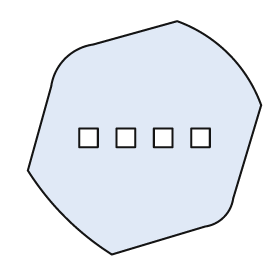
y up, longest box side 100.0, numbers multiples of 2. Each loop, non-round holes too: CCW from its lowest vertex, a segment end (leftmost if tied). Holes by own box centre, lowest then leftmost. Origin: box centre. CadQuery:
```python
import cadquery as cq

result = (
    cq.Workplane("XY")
    .moveTo(-14.0, -50.0)
    .lineTo(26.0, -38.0)
    .threePointArc((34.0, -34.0), (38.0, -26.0))
    .lineTo(50.0, 14.0)
    .threePointArc((36.0, 36.0), (14.0, 50.0))
    .lineTo(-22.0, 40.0)
    .threePointArc((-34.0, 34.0), (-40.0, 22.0))
    .lineTo(-50.0, -14.0)
    .threePointArc((-34.0, -34.0), (-14.0, -50.0))
    .close()
    .moveTo(-28.0, -4.0)
    .lineTo(-20.0, -4.0)
    .lineTo(-20.0, 4.0)
    .lineTo(-28.0, 4.0)
    .close()
    .moveTo(-12.0, -4.0)
    .lineTo(-4.0, -4.0)
    .lineTo(-4.0, 4.0)
    .lineTo(-12.0, 4.0)
    .close()
    .moveTo(4.0, -4.0)
    .lineTo(12.0, -4.0)
    .lineTo(12.0, 4.0)
    .lineTo(4.0, 4.0)
    .close()
    .moveTo(20.0, -4.0)
    .lineTo(28.0, -4.0)
    .lineTo(28.0, 4.0)
    .lineTo(20.0, 4.0)
    .close()
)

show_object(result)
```